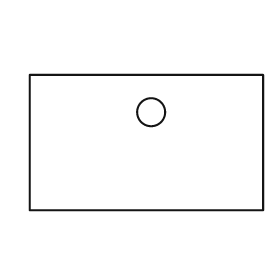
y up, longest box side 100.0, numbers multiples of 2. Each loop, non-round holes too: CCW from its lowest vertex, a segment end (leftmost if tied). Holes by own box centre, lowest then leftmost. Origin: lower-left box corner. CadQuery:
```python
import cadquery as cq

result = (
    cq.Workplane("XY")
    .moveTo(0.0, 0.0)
    .lineTo(100.0, 0.0)
    .lineTo(100.0, 58.0)
    .lineTo(0.0, 58.0)
    .close()
    .moveTo(52.0, 42.0)
    .circle(6.0)
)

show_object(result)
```